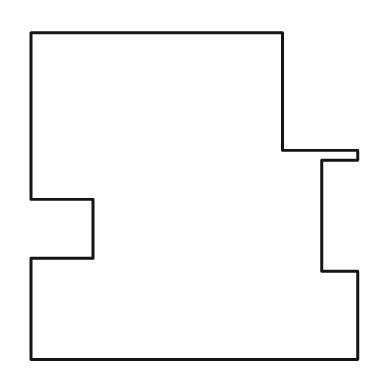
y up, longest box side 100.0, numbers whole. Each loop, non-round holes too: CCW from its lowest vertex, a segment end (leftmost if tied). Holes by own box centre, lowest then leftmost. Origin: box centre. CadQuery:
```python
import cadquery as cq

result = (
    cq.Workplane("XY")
    .moveTo(-50.0, -50.0)
    .lineTo(50.0, -50.0)
    .lineTo(50.0, -23.0)
    .lineTo(39.0, -23.0)
    .lineTo(39.0, 11.0)
    .lineTo(50.0, 11.0)
    .lineTo(50.0, 14.0)
    .lineTo(27.0, 14.0)
    .lineTo(27.0, 50.0)
    .lineTo(-50.0, 50.0)
    .lineTo(-50.0, -1.0)
    .lineTo(-31.0, -1.0)
    .lineTo(-31.0, -19.0)
    .lineTo(-50.0, -19.0)
    .close()
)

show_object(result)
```